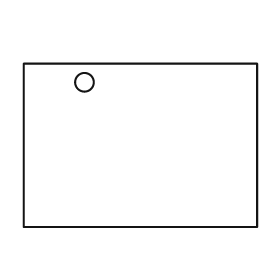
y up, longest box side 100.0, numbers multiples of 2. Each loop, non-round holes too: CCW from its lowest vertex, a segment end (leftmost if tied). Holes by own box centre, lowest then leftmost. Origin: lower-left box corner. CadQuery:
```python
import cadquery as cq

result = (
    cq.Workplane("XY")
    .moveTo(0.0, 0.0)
    .lineTo(100.0, 0.0)
    .lineTo(100.0, 70.0)
    .lineTo(0.0, 70.0)
    .close()
    .moveTo(26.0, 62.0)
    .circle(4.0)
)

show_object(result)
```